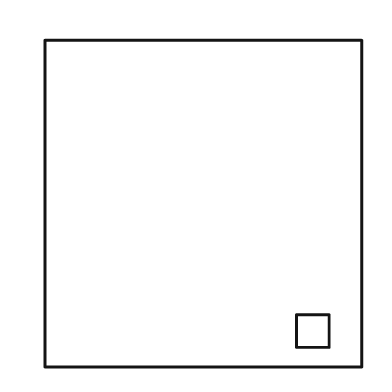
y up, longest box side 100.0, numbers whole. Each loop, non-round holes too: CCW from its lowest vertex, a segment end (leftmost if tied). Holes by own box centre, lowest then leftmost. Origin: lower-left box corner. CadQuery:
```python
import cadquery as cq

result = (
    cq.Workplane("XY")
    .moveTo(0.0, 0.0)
    .lineTo(97.0, 0.0)
    .lineTo(97.0, 100.0)
    .lineTo(0.0, 100.0)
    .close()
    .moveTo(77.0, 6.0)
    .lineTo(87.0, 6.0)
    .lineTo(87.0, 16.0)
    .lineTo(77.0, 16.0)
    .close()
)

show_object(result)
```